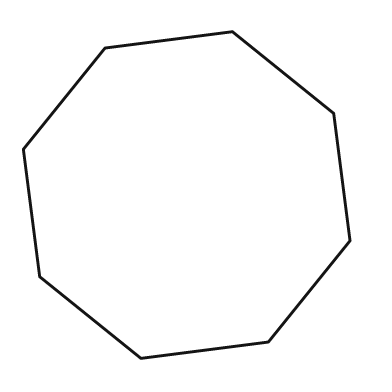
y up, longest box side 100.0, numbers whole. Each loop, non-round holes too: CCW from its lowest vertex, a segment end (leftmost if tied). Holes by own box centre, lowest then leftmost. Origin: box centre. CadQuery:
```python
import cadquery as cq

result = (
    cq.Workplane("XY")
    .moveTo(-14.0, -50.0)
    .lineTo(25.0, -45.0)
    .lineTo(50.0, -14.0)
    .lineTo(45.0, 25.0)
    .lineTo(14.0, 50.0)
    .lineTo(-25.0, 45.0)
    .lineTo(-50.0, 14.0)
    .lineTo(-45.0, -25.0)
    .close()
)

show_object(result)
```